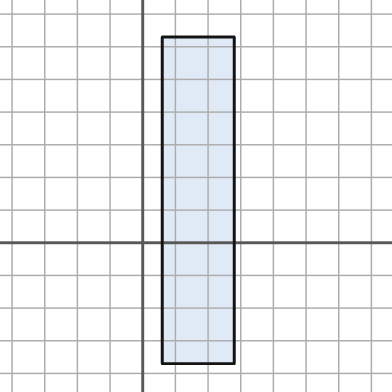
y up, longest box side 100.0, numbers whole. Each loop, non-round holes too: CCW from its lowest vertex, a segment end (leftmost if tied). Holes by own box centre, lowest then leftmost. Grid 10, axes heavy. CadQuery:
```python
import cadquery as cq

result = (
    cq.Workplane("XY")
    .moveTo(6.0, -37.0)
    .lineTo(28.0, -37.0)
    .lineTo(28.0, 63.0)
    .lineTo(6.0, 63.0)
    .close()
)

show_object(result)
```